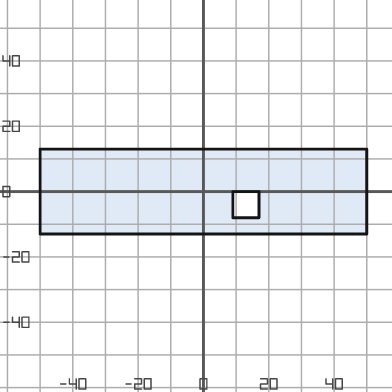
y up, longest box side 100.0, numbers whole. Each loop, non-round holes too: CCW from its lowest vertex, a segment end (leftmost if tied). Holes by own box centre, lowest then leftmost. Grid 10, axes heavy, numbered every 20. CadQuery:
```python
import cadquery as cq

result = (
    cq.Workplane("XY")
    .moveTo(-50.0, -13.0)
    .lineTo(50.0, -13.0)
    .lineTo(50.0, 13.0)
    .lineTo(-50.0, 13.0)
    .close()
    .moveTo(9.0, -8.0)
    .lineTo(17.0, -8.0)
    .lineTo(17.0, 0.0)
    .lineTo(9.0, 0.0)
    .close()
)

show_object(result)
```